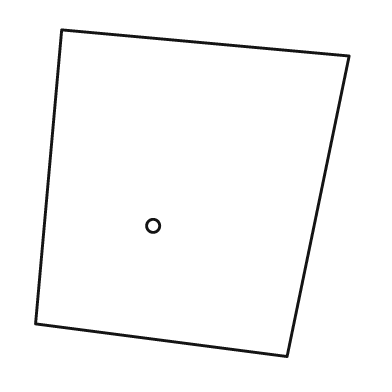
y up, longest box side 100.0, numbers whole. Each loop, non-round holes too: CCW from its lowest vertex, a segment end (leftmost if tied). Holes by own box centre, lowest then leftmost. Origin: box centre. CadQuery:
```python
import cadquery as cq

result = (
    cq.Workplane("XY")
    .moveTo(29.0, -50.0)
    .lineTo(48.0, 42.0)
    .lineTo(-40.0, 50.0)
    .lineTo(-48.0, -40.0)
    .close()
    .moveTo(-12.0, -10.0)
    .circle(2.0)
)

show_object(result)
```